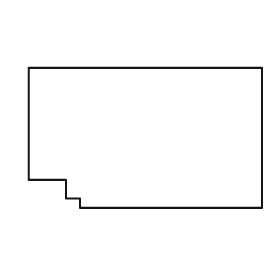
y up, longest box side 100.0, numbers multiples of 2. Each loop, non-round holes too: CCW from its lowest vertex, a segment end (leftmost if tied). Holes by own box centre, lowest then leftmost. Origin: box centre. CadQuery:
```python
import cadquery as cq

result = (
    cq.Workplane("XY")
    .moveTo(-28.0, -30.0)
    .lineTo(50.0, -30.0)
    .lineTo(50.0, 30.0)
    .lineTo(-50.0, 30.0)
    .lineTo(-50.0, -18.0)
    .lineTo(-34.0, -18.0)
    .lineTo(-34.0, -26.0)
    .lineTo(-28.0, -26.0)
    .close()
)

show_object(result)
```